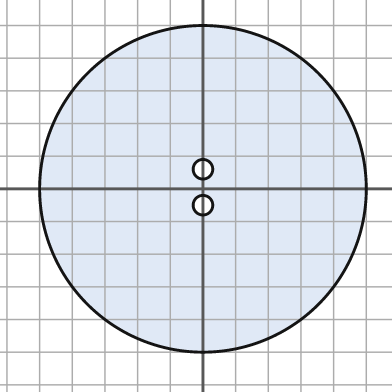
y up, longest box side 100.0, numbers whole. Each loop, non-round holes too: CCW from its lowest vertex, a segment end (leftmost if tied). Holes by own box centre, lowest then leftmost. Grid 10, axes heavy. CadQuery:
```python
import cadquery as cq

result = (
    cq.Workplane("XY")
    .moveTo(0.0, 0.0)
    .circle(50.0)
    .moveTo(0.0, -5.0)
    .circle(3.0)
    .moveTo(0.0, 6.0)
    .circle(3.0)
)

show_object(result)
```